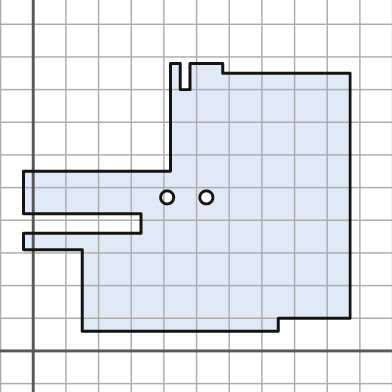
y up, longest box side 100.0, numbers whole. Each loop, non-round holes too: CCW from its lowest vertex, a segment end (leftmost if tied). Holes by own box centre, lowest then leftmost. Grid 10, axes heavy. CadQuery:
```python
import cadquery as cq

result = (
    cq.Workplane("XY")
    .moveTo(15.0, 6.0)
    .lineTo(75.0, 6.0)
    .lineTo(75.0, 10.0)
    .lineTo(97.0, 10.0)
    .lineTo(97.0, 85.0)
    .lineTo(58.0, 85.0)
    .lineTo(58.0, 88.0)
    .lineTo(48.0, 88.0)
    .lineTo(48.0, 80.0)
    .lineTo(45.0, 80.0)
    .lineTo(45.0, 88.0)
    .lineTo(42.0, 88.0)
    .lineTo(42.0, 55.0)
    .lineTo(-3.0, 55.0)
    .lineTo(-3.0, 42.0)
    .lineTo(33.0, 42.0)
    .lineTo(33.0, 36.0)
    .lineTo(-3.0, 36.0)
    .lineTo(-3.0, 31.0)
    .lineTo(15.0, 31.0)
    .close()
    .moveTo(41.0, 47.0)
    .circle(2.0)
    .moveTo(53.0, 47.0)
    .circle(2.0)
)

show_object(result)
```